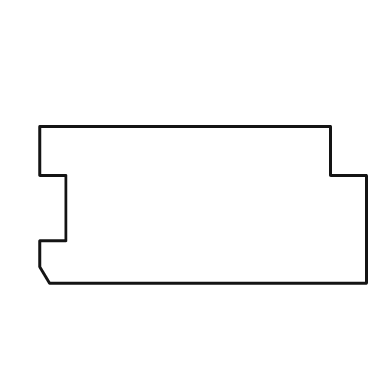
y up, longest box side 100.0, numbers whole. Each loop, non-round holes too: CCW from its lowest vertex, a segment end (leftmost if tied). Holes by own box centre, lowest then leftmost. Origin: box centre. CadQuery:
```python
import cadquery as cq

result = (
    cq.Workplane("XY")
    .moveTo(-47.0, -24.0)
    .lineTo(50.0, -24.0)
    .lineTo(50.0, 9.0)
    .lineTo(39.0, 9.0)
    .lineTo(39.0, 24.0)
    .lineTo(-50.0, 24.0)
    .lineTo(-50.0, 9.0)
    .lineTo(-42.0, 9.0)
    .lineTo(-42.0, -11.0)
    .lineTo(-50.0, -11.0)
    .lineTo(-50.0, -19.0)
    .close()
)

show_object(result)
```